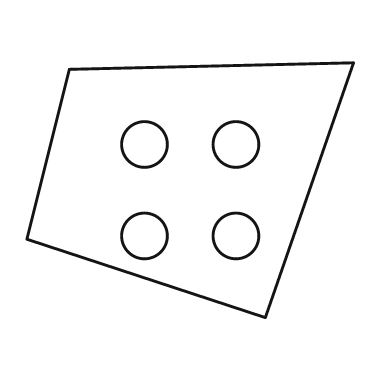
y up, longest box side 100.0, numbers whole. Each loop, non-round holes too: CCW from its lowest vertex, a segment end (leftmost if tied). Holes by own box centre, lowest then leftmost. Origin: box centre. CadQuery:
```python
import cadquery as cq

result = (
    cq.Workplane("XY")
    .moveTo(23.0, -39.0)
    .lineTo(50.0, 39.0)
    .lineTo(-37.0, 37.0)
    .lineTo(-50.0, -15.0)
    .close()
    .moveTo(-14.0, -14.0)
    .circle(7.0)
    .moveTo(14.0, -14.0)
    .circle(7.0)
    .moveTo(-14.0, 14.0)
    .circle(7.0)
    .moveTo(14.0, 14.0)
    .circle(7.0)
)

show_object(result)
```